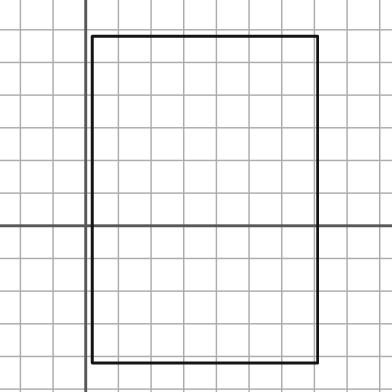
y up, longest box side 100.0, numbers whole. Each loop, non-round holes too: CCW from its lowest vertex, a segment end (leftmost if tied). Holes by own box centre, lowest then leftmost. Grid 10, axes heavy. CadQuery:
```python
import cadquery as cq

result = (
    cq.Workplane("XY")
    .moveTo(2.0, -42.0)
    .lineTo(71.0, -42.0)
    .lineTo(71.0, 58.0)
    .lineTo(2.0, 58.0)
    .close()
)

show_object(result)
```